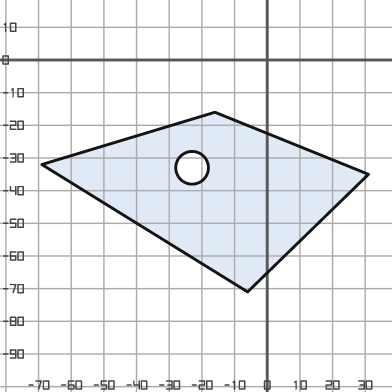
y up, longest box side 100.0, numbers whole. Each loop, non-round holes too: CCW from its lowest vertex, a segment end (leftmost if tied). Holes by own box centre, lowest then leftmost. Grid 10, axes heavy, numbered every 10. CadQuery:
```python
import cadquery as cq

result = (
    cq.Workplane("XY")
    .moveTo(-6.0, -71.0)
    .lineTo(31.0, -35.0)
    .lineTo(-16.0, -16.0)
    .lineTo(-69.0, -32.0)
    .close()
    .moveTo(-23.0, -33.0)
    .circle(5.0)
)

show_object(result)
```